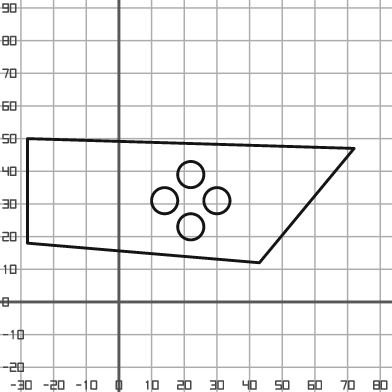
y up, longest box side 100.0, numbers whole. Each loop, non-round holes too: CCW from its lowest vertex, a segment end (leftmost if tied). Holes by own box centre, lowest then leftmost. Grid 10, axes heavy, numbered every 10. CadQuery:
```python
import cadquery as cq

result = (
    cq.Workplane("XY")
    .moveTo(43.0, 12.0)
    .lineTo(72.0, 47.0)
    .lineTo(-28.0, 50.0)
    .lineTo(-28.0, 18.0)
    .close()
    .moveTo(22.0, 23.0)
    .circle(4.0)
    .moveTo(14.0, 31.0)
    .circle(4.0)
    .moveTo(30.0, 31.0)
    .circle(4.0)
    .moveTo(22.0, 39.0)
    .circle(4.0)
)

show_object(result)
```